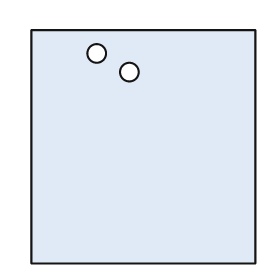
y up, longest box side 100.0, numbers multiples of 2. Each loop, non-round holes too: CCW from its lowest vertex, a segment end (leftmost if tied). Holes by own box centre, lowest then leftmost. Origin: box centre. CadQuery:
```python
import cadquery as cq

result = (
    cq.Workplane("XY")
    .moveTo(-48.0, -50.0)
    .lineTo(48.0, -50.0)
    .lineTo(48.0, 50.0)
    .lineTo(-48.0, 50.0)
    .close()
    .moveTo(-6.0, 32.0)
    .circle(4.0)
    .moveTo(-20.0, 40.0)
    .circle(4.0)
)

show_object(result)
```